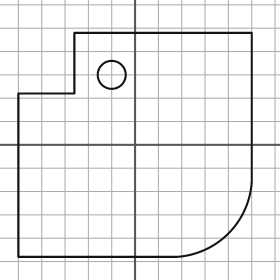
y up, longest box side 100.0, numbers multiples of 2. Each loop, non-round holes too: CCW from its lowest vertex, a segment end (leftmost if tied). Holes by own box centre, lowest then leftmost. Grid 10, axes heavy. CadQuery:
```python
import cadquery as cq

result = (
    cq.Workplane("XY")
    .moveTo(-50.0, -48.0)
    .lineTo(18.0, -48.0)
    .threePointArc((40.0, -38.0), (50.0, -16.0))
    .lineTo(50.0, 48.0)
    .lineTo(-26.0, 48.0)
    .lineTo(-26.0, 22.0)
    .lineTo(-50.0, 22.0)
    .close()
    .moveTo(-10.0, 30.0)
    .circle(6.0)
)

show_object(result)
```